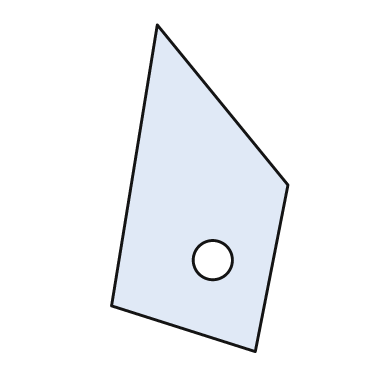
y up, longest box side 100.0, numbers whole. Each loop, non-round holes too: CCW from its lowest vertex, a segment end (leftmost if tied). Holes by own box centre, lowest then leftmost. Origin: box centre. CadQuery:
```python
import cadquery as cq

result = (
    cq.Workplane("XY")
    .moveTo(17.0, -50.0)
    .lineTo(27.0, 1.0)
    .lineTo(-13.0, 50.0)
    .lineTo(-27.0, -36.0)
    .close()
    .moveTo(4.0, -22.0)
    .circle(6.0)
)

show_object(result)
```